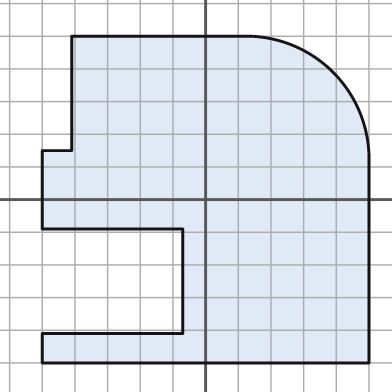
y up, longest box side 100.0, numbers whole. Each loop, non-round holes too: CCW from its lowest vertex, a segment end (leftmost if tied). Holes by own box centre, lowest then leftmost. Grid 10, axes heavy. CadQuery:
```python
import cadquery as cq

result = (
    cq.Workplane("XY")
    .moveTo(-50.0, -50.0)
    .lineTo(50.0, -50.0)
    .lineTo(50.0, 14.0)
    .threePointArc((39.0, 39.0), (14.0, 50.0))
    .lineTo(-41.0, 50.0)
    .lineTo(-41.0, 15.0)
    .lineTo(-50.0, 15.0)
    .lineTo(-50.0, -9.0)
    .lineTo(-7.0, -9.0)
    .lineTo(-7.0, -41.0)
    .lineTo(-50.0, -41.0)
    .close()
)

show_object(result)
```